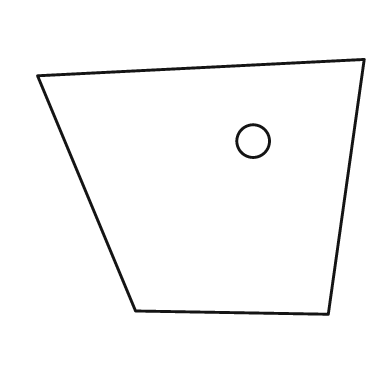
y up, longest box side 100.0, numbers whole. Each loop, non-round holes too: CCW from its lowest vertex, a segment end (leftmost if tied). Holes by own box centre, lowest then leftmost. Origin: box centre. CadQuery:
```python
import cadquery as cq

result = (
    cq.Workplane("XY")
    .moveTo(39.0, -39.0)
    .lineTo(50.0, 39.0)
    .lineTo(-50.0, 34.0)
    .lineTo(-20.0, -38.0)
    .close()
    .moveTo(16.0, 14.0)
    .circle(5.0)
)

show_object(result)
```